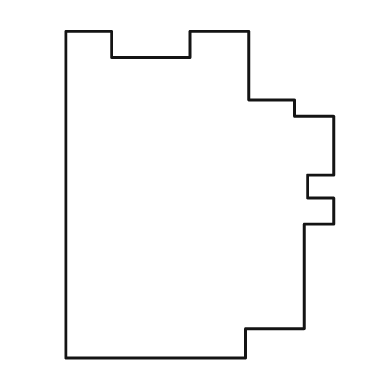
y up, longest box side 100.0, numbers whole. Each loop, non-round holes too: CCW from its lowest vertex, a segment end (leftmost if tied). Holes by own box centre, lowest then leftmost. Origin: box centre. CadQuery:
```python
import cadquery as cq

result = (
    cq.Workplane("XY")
    .moveTo(-41.0, -50.0)
    .lineTo(14.0, -50.0)
    .lineTo(14.0, -41.0)
    .lineTo(32.0, -41.0)
    .lineTo(32.0, -9.0)
    .lineTo(41.0, -9.0)
    .lineTo(41.0, -1.0)
    .lineTo(33.0, -1.0)
    .lineTo(33.0, 6.0)
    .lineTo(41.0, 6.0)
    .lineTo(41.0, 24.0)
    .lineTo(29.0, 24.0)
    .lineTo(29.0, 29.0)
    .lineTo(15.0, 29.0)
    .lineTo(15.0, 50.0)
    .lineTo(-3.0, 50.0)
    .lineTo(-3.0, 42.0)
    .lineTo(-27.0, 42.0)
    .lineTo(-27.0, 50.0)
    .lineTo(-41.0, 50.0)
    .close()
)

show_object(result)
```